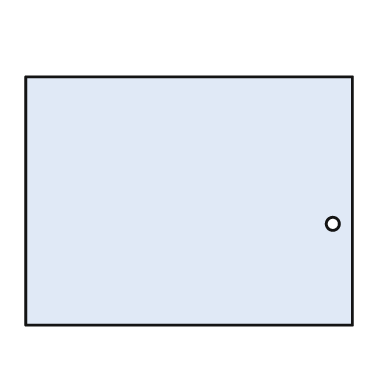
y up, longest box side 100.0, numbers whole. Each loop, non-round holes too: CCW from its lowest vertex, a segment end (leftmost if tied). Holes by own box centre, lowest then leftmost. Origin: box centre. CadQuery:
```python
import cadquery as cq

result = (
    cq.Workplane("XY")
    .moveTo(-50.0, -38.0)
    .lineTo(50.0, -38.0)
    .lineTo(50.0, 38.0)
    .lineTo(-50.0, 38.0)
    .close()
    .moveTo(44.0, -7.0)
    .circle(2.0)
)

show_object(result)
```